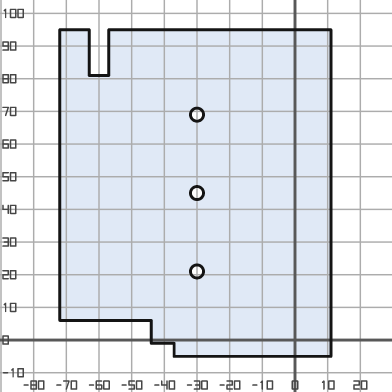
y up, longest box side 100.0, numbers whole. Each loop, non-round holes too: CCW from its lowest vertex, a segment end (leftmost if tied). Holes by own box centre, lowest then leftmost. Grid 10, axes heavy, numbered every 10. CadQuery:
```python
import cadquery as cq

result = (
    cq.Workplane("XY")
    .moveTo(-37.0, -5.0)
    .lineTo(11.0, -5.0)
    .lineTo(11.0, 95.0)
    .lineTo(-57.0, 95.0)
    .lineTo(-57.0, 81.0)
    .lineTo(-63.0, 81.0)
    .lineTo(-63.0, 95.0)
    .lineTo(-72.0, 95.0)
    .lineTo(-72.0, 6.0)
    .lineTo(-44.0, 6.0)
    .lineTo(-44.0, -1.0)
    .lineTo(-37.0, -1.0)
    .close()
    .moveTo(-30.0, 21.0)
    .circle(2.0)
    .moveTo(-30.0, 45.0)
    .circle(2.0)
    .moveTo(-30.0, 69.0)
    .circle(2.0)
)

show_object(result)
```